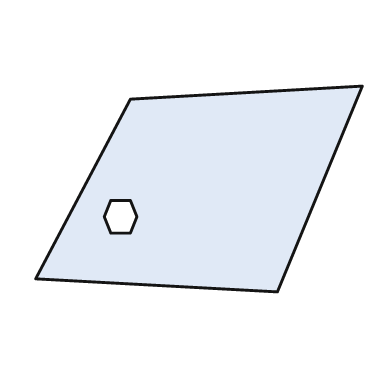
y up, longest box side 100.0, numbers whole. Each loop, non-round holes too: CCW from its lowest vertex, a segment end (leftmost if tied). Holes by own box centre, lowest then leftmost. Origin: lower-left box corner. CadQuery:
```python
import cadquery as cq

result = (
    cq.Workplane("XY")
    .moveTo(74.0, 0.0)
    .lineTo(100.0, 63.0)
    .lineTo(29.0, 59.0)
    .lineTo(0.0, 4.0)
    .close()
    .moveTo(23.0, 18.0)
    .lineTo(29.0, 18.0)
    .lineTo(31.0, 23.0)
    .lineTo(29.0, 28.0)
    .lineTo(23.0, 28.0)
    .lineTo(21.0, 23.0)
    .close()
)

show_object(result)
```